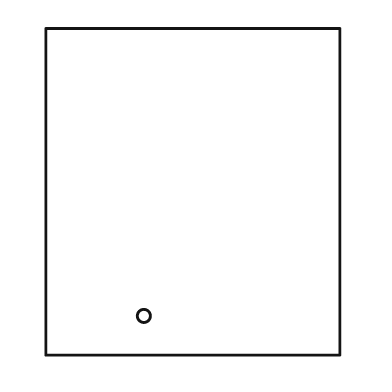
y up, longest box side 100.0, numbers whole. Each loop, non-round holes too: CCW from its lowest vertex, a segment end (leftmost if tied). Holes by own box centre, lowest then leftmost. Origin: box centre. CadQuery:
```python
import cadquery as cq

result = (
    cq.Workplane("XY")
    .moveTo(-45.0, -50.0)
    .lineTo(45.0, -50.0)
    .lineTo(45.0, 50.0)
    .lineTo(-45.0, 50.0)
    .close()
    .moveTo(-15.0, -38.0)
    .circle(2.0)
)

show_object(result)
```